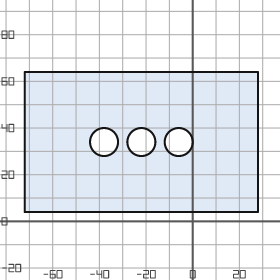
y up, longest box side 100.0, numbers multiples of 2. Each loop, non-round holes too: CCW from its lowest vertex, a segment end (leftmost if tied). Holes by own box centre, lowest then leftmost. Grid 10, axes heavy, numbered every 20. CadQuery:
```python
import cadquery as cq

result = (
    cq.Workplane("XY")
    .moveTo(-72.0, 4.0)
    .lineTo(28.0, 4.0)
    .lineTo(28.0, 64.0)
    .lineTo(-72.0, 64.0)
    .close()
    .moveTo(-38.0, 34.0)
    .circle(6.0)
    .moveTo(-22.0, 34.0)
    .circle(6.0)
    .moveTo(-6.0, 34.0)
    .circle(6.0)
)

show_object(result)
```